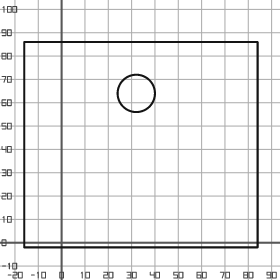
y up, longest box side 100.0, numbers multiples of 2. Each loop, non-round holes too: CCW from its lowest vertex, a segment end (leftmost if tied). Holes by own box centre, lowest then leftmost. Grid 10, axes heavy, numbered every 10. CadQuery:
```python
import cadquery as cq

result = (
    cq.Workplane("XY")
    .moveTo(-16.0, -2.0)
    .lineTo(84.0, -2.0)
    .lineTo(84.0, 86.0)
    .lineTo(-16.0, 86.0)
    .close()
    .moveTo(32.0, 64.0)
    .circle(8.0)
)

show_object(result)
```